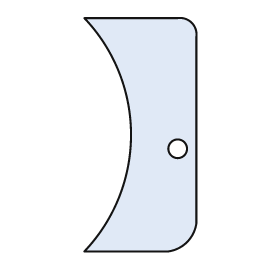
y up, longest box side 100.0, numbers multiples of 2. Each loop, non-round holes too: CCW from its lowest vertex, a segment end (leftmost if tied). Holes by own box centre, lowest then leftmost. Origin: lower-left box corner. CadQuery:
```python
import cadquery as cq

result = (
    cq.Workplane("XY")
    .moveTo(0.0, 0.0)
    .lineTo(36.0, 0.0)
    .threePointArc((44.0, 4.0), (48.0, 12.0))
    .lineTo(48.0, 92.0)
    .threePointArc((46.0, 98.0), (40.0, 100.0))
    .lineTo(0.0, 100.0)
    .threePointArc((20.0, 50.0), (0.0, 0.0))
    .close()
    .moveTo(40.0, 44.0)
    .circle(4.0)
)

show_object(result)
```